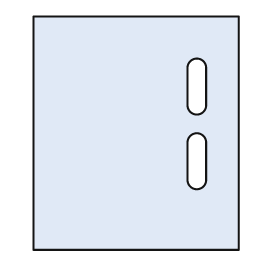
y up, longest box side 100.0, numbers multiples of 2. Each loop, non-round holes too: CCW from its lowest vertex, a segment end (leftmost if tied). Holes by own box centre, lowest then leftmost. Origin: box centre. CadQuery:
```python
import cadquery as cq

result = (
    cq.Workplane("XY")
    .moveTo(-44.0, -50.0)
    .lineTo(44.0, -50.0)
    .lineTo(44.0, 50.0)
    .lineTo(-44.0, 50.0)
    .close()
    .moveTo(22.0, -20.0)
    .threePointArc((26.0, -24.0), (30.0, -20.0))
    .lineTo(30.0, -4.0)
    .threePointArc((26.0, 0.0), (22.0, -4.0))
    .close()
    .moveTo(22.0, 12.0)
    .threePointArc((26.0, 8.0), (30.0, 12.0))
    .lineTo(30.0, 28.0)
    .threePointArc((26.0, 32.0), (22.0, 28.0))
    .close()
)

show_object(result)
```